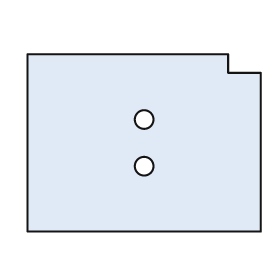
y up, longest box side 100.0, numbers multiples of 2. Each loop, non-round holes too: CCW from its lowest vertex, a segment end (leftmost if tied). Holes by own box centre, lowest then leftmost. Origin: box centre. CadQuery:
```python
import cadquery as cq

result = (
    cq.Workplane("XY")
    .moveTo(-50.0, -38.0)
    .lineTo(50.0, -38.0)
    .lineTo(50.0, 30.0)
    .lineTo(36.0, 30.0)
    .lineTo(36.0, 38.0)
    .lineTo(-50.0, 38.0)
    .close()
    .moveTo(0.0, -10.0)
    .circle(4.0)
    .moveTo(0.0, 10.0)
    .circle(4.0)
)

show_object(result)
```